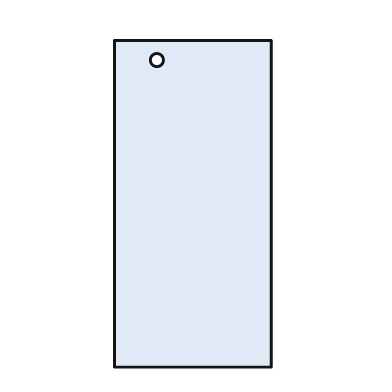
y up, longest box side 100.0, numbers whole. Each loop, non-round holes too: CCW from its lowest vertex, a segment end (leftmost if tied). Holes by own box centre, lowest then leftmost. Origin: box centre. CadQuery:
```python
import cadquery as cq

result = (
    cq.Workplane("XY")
    .moveTo(-24.0, -50.0)
    .lineTo(24.0, -50.0)
    .lineTo(24.0, 50.0)
    .lineTo(-24.0, 50.0)
    .close()
    .moveTo(-11.0, 44.0)
    .circle(2.0)
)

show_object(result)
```